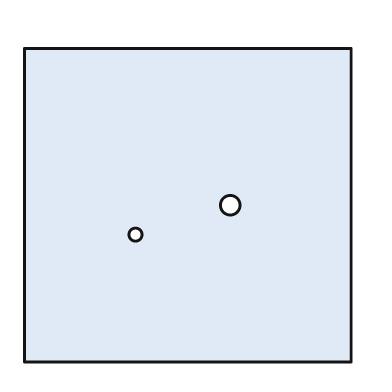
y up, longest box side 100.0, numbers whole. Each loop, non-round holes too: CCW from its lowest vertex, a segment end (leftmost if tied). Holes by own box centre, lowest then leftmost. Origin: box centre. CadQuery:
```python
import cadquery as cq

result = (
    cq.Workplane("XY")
    .moveTo(-50.0, -48.0)
    .lineTo(50.0, -48.0)
    .lineTo(50.0, 48.0)
    .lineTo(-50.0, 48.0)
    .close()
    .moveTo(-16.0, -9.0)
    .circle(2.0)
    .moveTo(13.0, 0.0)
    .circle(3.0)
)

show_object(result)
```